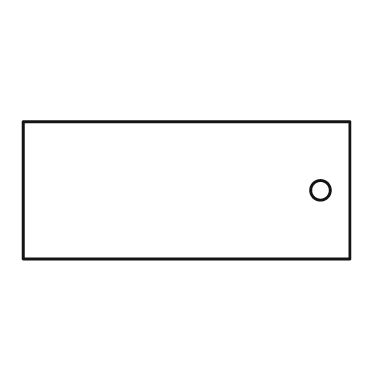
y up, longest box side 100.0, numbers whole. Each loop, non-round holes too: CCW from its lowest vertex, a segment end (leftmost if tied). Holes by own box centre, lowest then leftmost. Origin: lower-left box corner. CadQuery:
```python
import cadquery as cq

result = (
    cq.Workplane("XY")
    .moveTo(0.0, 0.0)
    .lineTo(100.0, 0.0)
    .lineTo(100.0, 42.0)
    .lineTo(0.0, 42.0)
    .close()
    .moveTo(91.0, 21.0)
    .circle(3.0)
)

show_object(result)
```